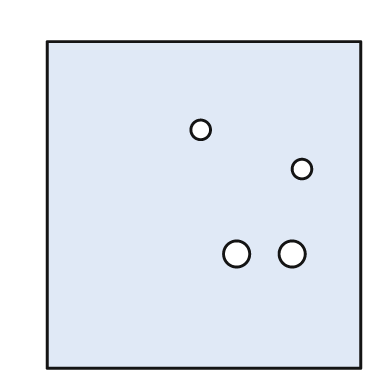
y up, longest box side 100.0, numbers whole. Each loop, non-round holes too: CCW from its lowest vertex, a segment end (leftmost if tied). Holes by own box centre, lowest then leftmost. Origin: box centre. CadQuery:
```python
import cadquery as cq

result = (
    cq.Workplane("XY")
    .moveTo(-48.0, -50.0)
    .lineTo(48.0, -50.0)
    .lineTo(48.0, 50.0)
    .lineTo(-48.0, 50.0)
    .close()
    .moveTo(10.0, -15.0)
    .circle(4.0)
    .moveTo(27.0, -15.0)
    .circle(4.0)
    .moveTo(30.0, 11.0)
    .circle(3.0)
    .moveTo(-1.0, 23.0)
    .circle(3.0)
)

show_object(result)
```